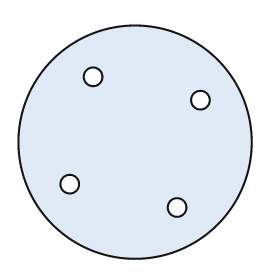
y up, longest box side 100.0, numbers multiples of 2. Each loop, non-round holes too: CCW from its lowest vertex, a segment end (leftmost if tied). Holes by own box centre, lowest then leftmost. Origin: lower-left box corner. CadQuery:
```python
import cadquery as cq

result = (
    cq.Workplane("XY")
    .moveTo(50.0, 50.0)
    .circle(50.0)
    .moveTo(68.0, 22.0)
    .circle(4.0)
    .moveTo(22.0, 32.0)
    .circle(4.0)
    .moveTo(78.0, 68.0)
    .circle(4.0)
    .moveTo(32.0, 78.0)
    .circle(4.0)
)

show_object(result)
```